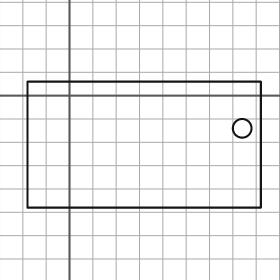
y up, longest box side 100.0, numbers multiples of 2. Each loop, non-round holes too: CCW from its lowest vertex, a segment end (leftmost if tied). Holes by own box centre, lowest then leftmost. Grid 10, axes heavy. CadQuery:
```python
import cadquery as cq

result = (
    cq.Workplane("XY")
    .moveTo(-18.0, -48.0)
    .lineTo(82.0, -48.0)
    .lineTo(82.0, 6.0)
    .lineTo(-18.0, 6.0)
    .close()
    .moveTo(74.0, -14.0)
    .circle(4.0)
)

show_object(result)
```